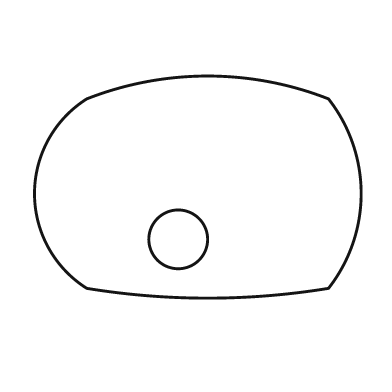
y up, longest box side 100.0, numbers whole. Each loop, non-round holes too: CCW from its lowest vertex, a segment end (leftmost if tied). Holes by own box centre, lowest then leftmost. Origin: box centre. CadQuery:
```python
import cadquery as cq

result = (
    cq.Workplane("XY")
    .moveTo(-34.0, -31.0)
    .threePointArc((3.0, -34.0), (40.0, -31.0))
    .threePointArc((50.0, -2.0), (40.0, 27.0))
    .threePointArc((3.0, 34.0), (-34.0, 27.0))
    .threePointArc((-50.0, -2.0), (-34.0, -31.0))
    .close()
    .moveTo(-6.0, -16.0)
    .circle(9.0)
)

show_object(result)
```